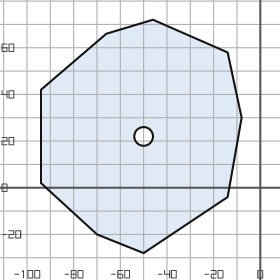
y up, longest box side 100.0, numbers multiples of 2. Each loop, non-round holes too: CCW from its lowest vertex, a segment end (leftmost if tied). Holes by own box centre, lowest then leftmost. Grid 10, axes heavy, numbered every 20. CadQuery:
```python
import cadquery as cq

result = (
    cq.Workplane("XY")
    .moveTo(-50.0, -28.0)
    .lineTo(-14.0, -4.0)
    .lineTo(-8.0, 30.0)
    .lineTo(-14.0, 58.0)
    .lineTo(-46.0, 72.0)
    .lineTo(-66.0, 66.0)
    .lineTo(-94.0, 42.0)
    .lineTo(-94.0, 2.0)
    .lineTo(-70.0, -20.0)
    .close()
    .moveTo(-50.0, 22.0)
    .circle(4.0)
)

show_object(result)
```